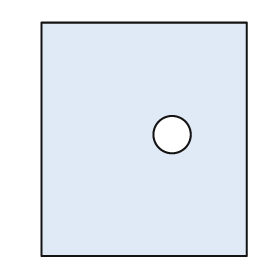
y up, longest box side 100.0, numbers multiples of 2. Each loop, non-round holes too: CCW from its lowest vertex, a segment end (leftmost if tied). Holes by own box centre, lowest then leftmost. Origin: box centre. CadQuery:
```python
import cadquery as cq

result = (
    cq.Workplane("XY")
    .moveTo(-44.0, -50.0)
    .lineTo(44.0, -50.0)
    .lineTo(44.0, 50.0)
    .lineTo(-44.0, 50.0)
    .close()
    .moveTo(12.0, 2.0)
    .circle(8.0)
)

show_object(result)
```